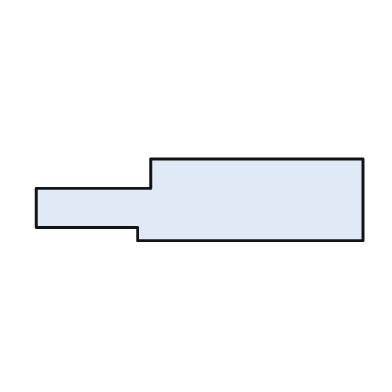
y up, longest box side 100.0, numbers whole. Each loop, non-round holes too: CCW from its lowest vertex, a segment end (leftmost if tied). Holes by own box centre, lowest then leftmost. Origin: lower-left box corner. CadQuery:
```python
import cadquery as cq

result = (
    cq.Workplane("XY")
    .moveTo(31.0, 0.0)
    .lineTo(100.0, 0.0)
    .lineTo(100.0, 25.0)
    .lineTo(35.0, 25.0)
    .lineTo(35.0, 16.0)
    .lineTo(0.0, 16.0)
    .lineTo(0.0, 4.0)
    .lineTo(31.0, 4.0)
    .close()
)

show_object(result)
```